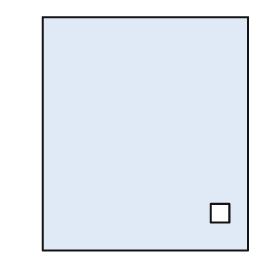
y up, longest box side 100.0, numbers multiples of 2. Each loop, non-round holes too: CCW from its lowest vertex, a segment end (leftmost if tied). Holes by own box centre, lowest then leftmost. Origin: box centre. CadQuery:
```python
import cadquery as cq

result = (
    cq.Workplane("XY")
    .moveTo(-44.0, -50.0)
    .lineTo(44.0, -50.0)
    .lineTo(44.0, 50.0)
    .lineTo(-44.0, 50.0)
    .close()
    .moveTo(28.0, -38.0)
    .lineTo(36.0, -38.0)
    .lineTo(36.0, -30.0)
    .lineTo(28.0, -30.0)
    .close()
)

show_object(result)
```